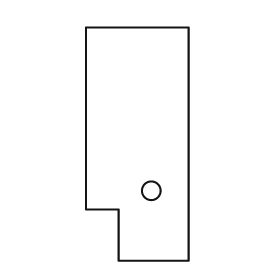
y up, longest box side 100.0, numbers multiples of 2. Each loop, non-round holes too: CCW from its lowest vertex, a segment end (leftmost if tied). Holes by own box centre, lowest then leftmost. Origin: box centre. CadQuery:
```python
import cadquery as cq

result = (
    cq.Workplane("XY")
    .moveTo(-8.0, -50.0)
    .lineTo(22.0, -50.0)
    .lineTo(22.0, 50.0)
    .lineTo(-22.0, 50.0)
    .lineTo(-22.0, -28.0)
    .lineTo(-8.0, -28.0)
    .close()
    .moveTo(6.0, -20.0)
    .circle(4.0)
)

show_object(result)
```